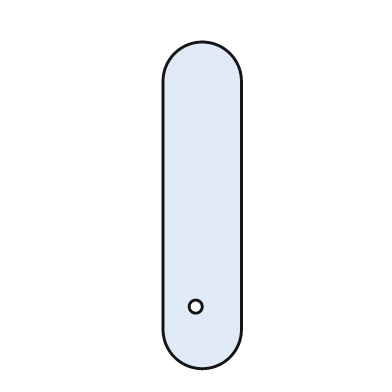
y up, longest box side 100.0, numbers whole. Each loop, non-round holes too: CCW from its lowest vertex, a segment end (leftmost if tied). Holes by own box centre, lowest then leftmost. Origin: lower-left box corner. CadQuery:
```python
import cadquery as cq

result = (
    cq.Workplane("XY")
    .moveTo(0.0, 12.0)
    .threePointArc((12.0, 0.0), (24.0, 12.0))
    .lineTo(24.0, 88.0)
    .threePointArc((12.0, 100.0), (0.0, 88.0))
    .close()
    .moveTo(10.0, 19.0)
    .circle(2.0)
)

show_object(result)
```